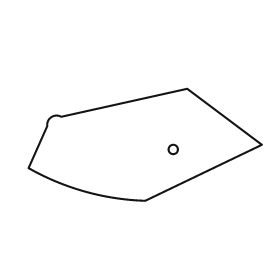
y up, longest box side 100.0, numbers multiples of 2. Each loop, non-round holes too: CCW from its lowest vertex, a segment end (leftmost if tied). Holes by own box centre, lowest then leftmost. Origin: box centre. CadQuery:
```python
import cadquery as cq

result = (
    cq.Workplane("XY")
    .moveTo(0.0, -24.0)
    .lineTo(50.0, 0.0)
    .lineTo(18.0, 24.0)
    .lineTo(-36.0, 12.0)
    .threePointArc((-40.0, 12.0), (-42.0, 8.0))
    .lineTo(-50.0, -10.0)
    .threePointArc((-26.0, -20.0), (0.0, -24.0))
    .close()
    .moveTo(12.0, -2.0)
    .circle(2.0)
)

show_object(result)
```